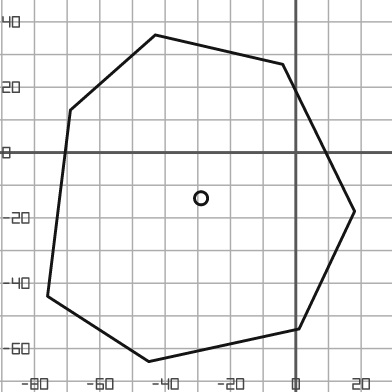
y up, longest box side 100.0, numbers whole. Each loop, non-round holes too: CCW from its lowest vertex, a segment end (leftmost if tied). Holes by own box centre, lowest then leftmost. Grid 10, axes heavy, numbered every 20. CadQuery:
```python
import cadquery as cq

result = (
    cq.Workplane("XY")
    .moveTo(-45.0, -64.0)
    .lineTo(1.0, -54.0)
    .lineTo(18.0, -18.0)
    .lineTo(-4.0, 27.0)
    .lineTo(-43.0, 36.0)
    .lineTo(-69.0, 13.0)
    .lineTo(-76.0, -44.0)
    .close()
    .moveTo(-29.0, -14.0)
    .circle(2.0)
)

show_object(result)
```